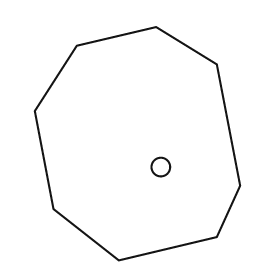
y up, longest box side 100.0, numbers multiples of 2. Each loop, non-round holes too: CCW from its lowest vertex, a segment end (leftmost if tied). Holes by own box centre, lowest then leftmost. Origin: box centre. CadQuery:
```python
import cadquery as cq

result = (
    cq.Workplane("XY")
    .moveTo(-8.0, -50.0)
    .lineTo(34.0, -40.0)
    .lineTo(44.0, -18.0)
    .lineTo(34.0, 34.0)
    .lineTo(8.0, 50.0)
    .lineTo(-26.0, 42.0)
    .lineTo(-44.0, 14.0)
    .lineTo(-36.0, -28.0)
    .close()
    .moveTo(10.0, -10.0)
    .circle(4.0)
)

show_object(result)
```